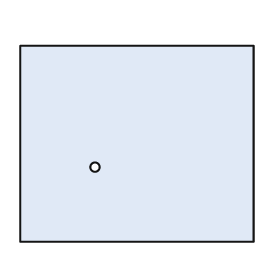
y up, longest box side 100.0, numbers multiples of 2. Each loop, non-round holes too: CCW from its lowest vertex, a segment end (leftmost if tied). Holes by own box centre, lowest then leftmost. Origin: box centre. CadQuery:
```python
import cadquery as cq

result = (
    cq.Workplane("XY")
    .moveTo(-50.0, -42.0)
    .lineTo(50.0, -42.0)
    .lineTo(50.0, 42.0)
    .lineTo(-50.0, 42.0)
    .close()
    .moveTo(-18.0, -10.0)
    .circle(2.0)
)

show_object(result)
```